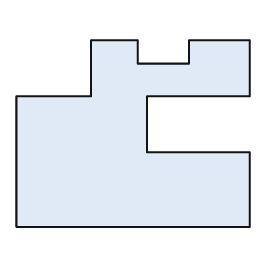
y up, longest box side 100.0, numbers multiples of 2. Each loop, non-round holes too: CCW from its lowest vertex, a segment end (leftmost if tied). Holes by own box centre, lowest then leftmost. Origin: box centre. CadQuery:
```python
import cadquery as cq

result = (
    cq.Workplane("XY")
    .moveTo(-50.0, -40.0)
    .lineTo(50.0, -40.0)
    .lineTo(50.0, -8.0)
    .lineTo(6.0, -8.0)
    .lineTo(6.0, 16.0)
    .lineTo(50.0, 16.0)
    .lineTo(50.0, 40.0)
    .lineTo(24.0, 40.0)
    .lineTo(24.0, 30.0)
    .lineTo(2.0, 30.0)
    .lineTo(2.0, 40.0)
    .lineTo(-18.0, 40.0)
    .lineTo(-18.0, 16.0)
    .lineTo(-50.0, 16.0)
    .close()
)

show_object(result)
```